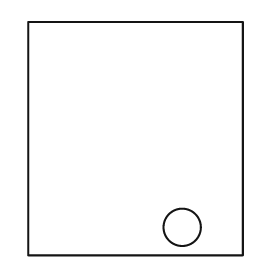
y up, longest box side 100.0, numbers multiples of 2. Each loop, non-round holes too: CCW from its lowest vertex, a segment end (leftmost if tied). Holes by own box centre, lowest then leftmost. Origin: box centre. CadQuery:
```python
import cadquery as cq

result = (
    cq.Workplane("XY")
    .moveTo(-46.0, -50.0)
    .lineTo(46.0, -50.0)
    .lineTo(46.0, 50.0)
    .lineTo(-46.0, 50.0)
    .close()
    .moveTo(20.0, -38.0)
    .circle(8.0)
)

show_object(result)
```